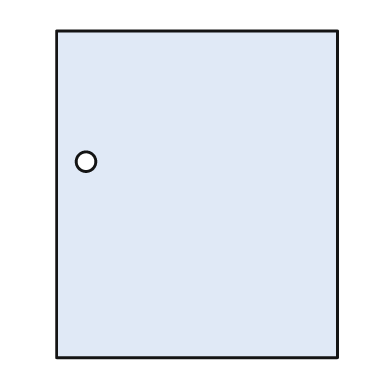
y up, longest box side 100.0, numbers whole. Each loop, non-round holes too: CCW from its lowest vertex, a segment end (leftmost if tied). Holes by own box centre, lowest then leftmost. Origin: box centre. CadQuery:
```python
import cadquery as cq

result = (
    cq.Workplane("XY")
    .moveTo(-43.0, -50.0)
    .lineTo(43.0, -50.0)
    .lineTo(43.0, 50.0)
    .lineTo(-43.0, 50.0)
    .close()
    .moveTo(-34.0, 10.0)
    .circle(3.0)
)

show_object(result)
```